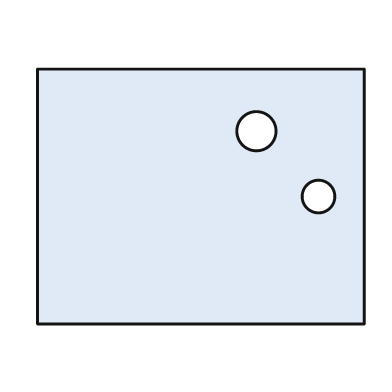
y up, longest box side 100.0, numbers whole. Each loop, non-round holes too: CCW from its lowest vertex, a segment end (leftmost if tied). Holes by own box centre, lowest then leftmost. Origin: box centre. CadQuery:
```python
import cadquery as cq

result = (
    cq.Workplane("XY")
    .moveTo(-50.0, -39.0)
    .lineTo(50.0, -39.0)
    .lineTo(50.0, 39.0)
    .lineTo(-50.0, 39.0)
    .close()
    .moveTo(36.0, 0.0)
    .circle(5.0)
    .moveTo(17.0, 20.0)
    .circle(6.0)
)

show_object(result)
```